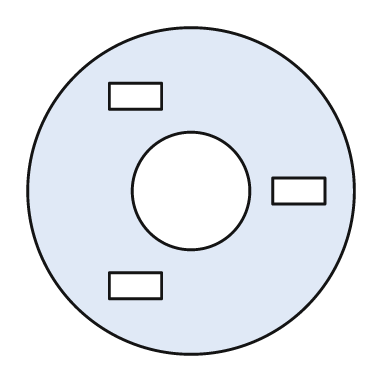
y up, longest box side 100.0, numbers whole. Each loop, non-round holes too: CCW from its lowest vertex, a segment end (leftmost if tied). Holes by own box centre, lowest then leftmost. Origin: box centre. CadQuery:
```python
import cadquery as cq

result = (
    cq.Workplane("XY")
    .moveTo(0.0, 0.0)
    .circle(50.0)
    .moveTo(-25.0, -33.0)
    .lineTo(-9.0, -33.0)
    .lineTo(-9.0, -25.0)
    .lineTo(-25.0, -25.0)
    .close()
    .moveTo(0.0, 0.0)
    .circle(18.0)
    .moveTo(25.0, -4.0)
    .lineTo(41.0, -4.0)
    .lineTo(41.0, 4.0)
    .lineTo(25.0, 4.0)
    .close()
    .moveTo(-25.0, 25.0)
    .lineTo(-9.0, 25.0)
    .lineTo(-9.0, 33.0)
    .lineTo(-25.0, 33.0)
    .close()
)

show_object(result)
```